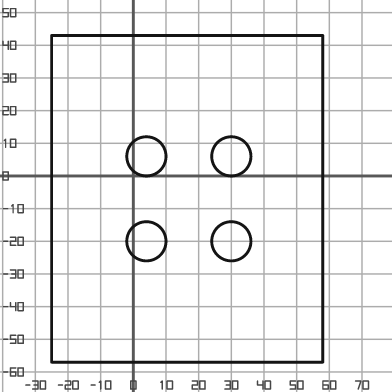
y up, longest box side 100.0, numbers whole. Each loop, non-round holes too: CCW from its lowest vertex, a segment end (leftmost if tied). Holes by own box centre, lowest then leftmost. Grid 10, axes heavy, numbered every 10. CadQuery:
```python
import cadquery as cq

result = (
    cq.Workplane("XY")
    .moveTo(-25.0, -57.0)
    .lineTo(58.0, -57.0)
    .lineTo(58.0, 43.0)
    .lineTo(-25.0, 43.0)
    .close()
    .moveTo(4.0, -20.0)
    .circle(6.0)
    .moveTo(30.0, -20.0)
    .circle(6.0)
    .moveTo(4.0, 6.0)
    .circle(6.0)
    .moveTo(30.0, 6.0)
    .circle(6.0)
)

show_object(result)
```